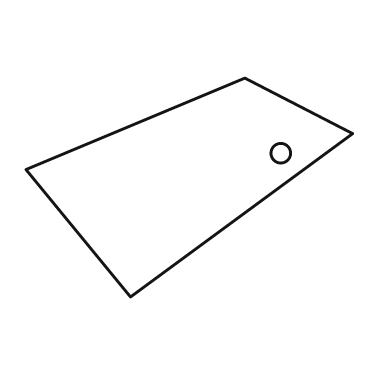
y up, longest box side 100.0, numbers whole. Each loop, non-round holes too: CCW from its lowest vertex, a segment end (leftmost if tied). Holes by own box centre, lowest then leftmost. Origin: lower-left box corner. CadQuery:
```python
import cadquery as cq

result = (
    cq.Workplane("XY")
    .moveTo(32.0, 0.0)
    .lineTo(100.0, 50.0)
    .lineTo(67.0, 67.0)
    .lineTo(0.0, 39.0)
    .close()
    .moveTo(78.0, 44.0)
    .circle(3.0)
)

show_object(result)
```